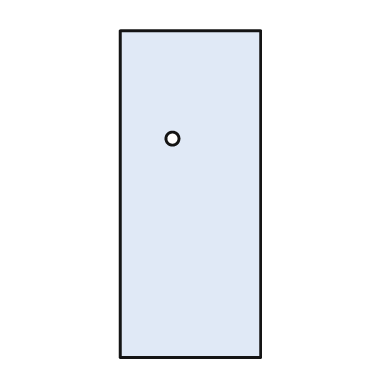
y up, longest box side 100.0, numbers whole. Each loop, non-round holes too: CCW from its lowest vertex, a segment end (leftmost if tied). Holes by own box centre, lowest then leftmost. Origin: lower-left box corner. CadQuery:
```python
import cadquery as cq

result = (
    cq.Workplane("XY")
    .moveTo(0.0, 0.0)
    .lineTo(43.0, 0.0)
    .lineTo(43.0, 100.0)
    .lineTo(0.0, 100.0)
    .close()
    .moveTo(16.0, 67.0)
    .circle(2.0)
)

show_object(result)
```